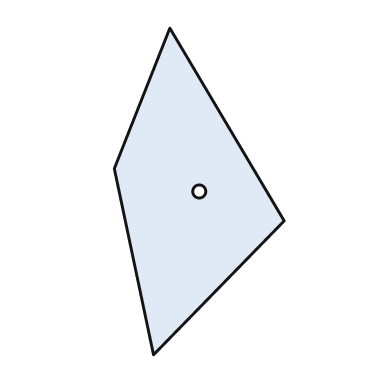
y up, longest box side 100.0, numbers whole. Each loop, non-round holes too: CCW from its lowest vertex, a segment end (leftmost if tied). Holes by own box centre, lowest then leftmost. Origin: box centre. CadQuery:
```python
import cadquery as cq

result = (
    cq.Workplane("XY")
    .moveTo(-14.0, -50.0)
    .lineTo(26.0, -9.0)
    .lineTo(-9.0, 50.0)
    .lineTo(-26.0, 7.0)
    .close()
    .moveTo(0.0, 0.0)
    .circle(2.0)
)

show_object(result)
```